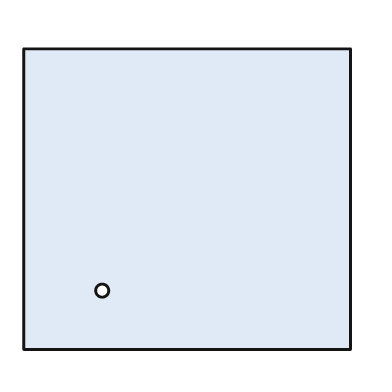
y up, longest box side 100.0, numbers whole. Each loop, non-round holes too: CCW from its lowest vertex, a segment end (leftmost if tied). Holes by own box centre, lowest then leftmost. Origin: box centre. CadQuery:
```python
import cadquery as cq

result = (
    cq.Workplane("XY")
    .moveTo(-50.0, -46.0)
    .lineTo(50.0, -46.0)
    .lineTo(50.0, 46.0)
    .lineTo(-50.0, 46.0)
    .close()
    .moveTo(-26.0, -28.0)
    .circle(2.0)
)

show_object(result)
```